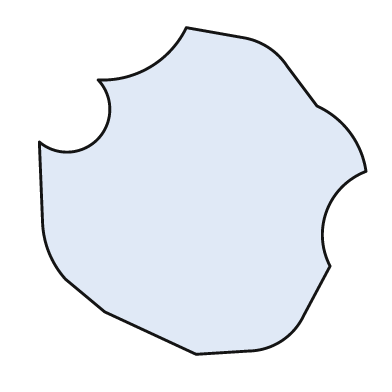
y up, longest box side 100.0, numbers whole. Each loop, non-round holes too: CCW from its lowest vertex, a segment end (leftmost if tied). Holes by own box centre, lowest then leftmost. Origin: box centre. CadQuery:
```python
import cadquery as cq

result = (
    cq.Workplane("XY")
    .moveTo(-2.0, -50.0)
    .lineTo(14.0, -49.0)
    .threePointArc((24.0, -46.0), (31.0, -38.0))
    .lineTo(39.0, -23.0)
    .threePointArc((38.0, -6.0), (50.0, 6.0))
    .threePointArc((45.0, 18.0), (35.0, 26.0))
    .lineTo(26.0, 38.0)
    .threePointArc((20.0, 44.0), (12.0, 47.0))
    .lineTo(-5.0, 50.0)
    .threePointArc((-16.0, 38.0), (-32.0, 34.0))
    .threePointArc((-32.0, 16.0), (-50.0, 15.0))
    .lineTo(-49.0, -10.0)
    .threePointArc((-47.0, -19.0), (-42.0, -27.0))
    .lineTo(-30.0, -37.0)
    .close()
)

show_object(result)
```